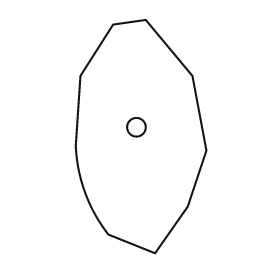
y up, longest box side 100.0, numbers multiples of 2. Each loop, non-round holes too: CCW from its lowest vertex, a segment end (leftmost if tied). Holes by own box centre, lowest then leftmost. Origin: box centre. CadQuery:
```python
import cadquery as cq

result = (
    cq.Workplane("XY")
    .moveTo(6.0, -50.0)
    .lineTo(20.0, -30.0)
    .lineTo(28.0, -6.0)
    .lineTo(22.0, 26.0)
    .lineTo(2.0, 50.0)
    .lineTo(-12.0, 48.0)
    .lineTo(-26.0, 26.0)
    .lineTo(-28.0, -4.0)
    .threePointArc((-24.0, -24.0), (-14.0, -42.0))
    .close()
    .moveTo(-2.0, 4.0)
    .circle(4.0)
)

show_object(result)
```